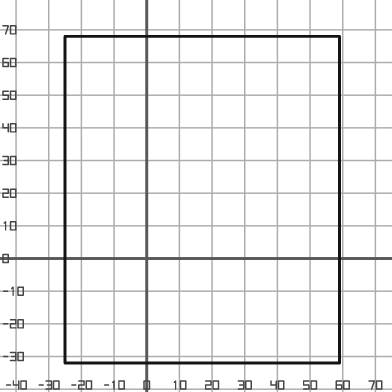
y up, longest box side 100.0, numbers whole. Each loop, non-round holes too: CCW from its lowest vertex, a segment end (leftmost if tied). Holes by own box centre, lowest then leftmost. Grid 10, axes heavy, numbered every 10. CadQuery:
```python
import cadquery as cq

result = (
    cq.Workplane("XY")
    .moveTo(-25.0, -32.0)
    .lineTo(59.0, -32.0)
    .lineTo(59.0, 68.0)
    .lineTo(-25.0, 68.0)
    .close()
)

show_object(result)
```